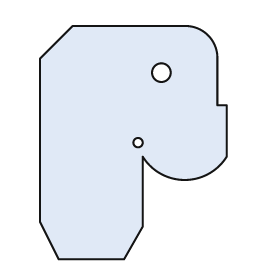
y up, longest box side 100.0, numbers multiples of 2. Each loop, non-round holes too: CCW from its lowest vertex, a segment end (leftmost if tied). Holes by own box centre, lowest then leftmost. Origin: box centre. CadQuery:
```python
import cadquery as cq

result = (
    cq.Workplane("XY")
    .moveTo(-32.0, -50.0)
    .lineTo(-4.0, -50.0)
    .lineTo(4.0, -36.0)
    .lineTo(4.0, -6.0)
    .threePointArc((22.0, -16.0), (40.0, -6.0))
    .lineTo(40.0, 16.0)
    .lineTo(36.0, 16.0)
    .lineTo(36.0, 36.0)
    .threePointArc((32.0, 46.0), (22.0, 50.0))
    .lineTo(-26.0, 50.0)
    .lineTo(-40.0, 36.0)
    .lineTo(-40.0, -34.0)
    .close()
    .moveTo(2.0, 0.0)
    .circle(2.0)
    .moveTo(12.0, 30.0)
    .circle(4.0)
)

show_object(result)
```